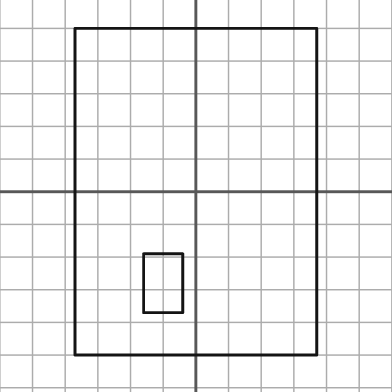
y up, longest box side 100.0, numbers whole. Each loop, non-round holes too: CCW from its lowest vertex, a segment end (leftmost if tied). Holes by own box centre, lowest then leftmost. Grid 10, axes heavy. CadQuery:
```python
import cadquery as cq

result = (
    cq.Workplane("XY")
    .moveTo(-37.0, -50.0)
    .lineTo(37.0, -50.0)
    .lineTo(37.0, 50.0)
    .lineTo(-37.0, 50.0)
    .close()
    .moveTo(-16.0, -37.0)
    .lineTo(-4.0, -37.0)
    .lineTo(-4.0, -19.0)
    .lineTo(-16.0, -19.0)
    .close()
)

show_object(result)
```